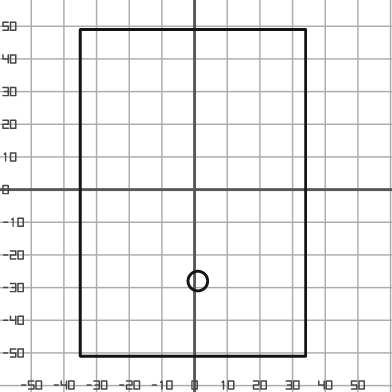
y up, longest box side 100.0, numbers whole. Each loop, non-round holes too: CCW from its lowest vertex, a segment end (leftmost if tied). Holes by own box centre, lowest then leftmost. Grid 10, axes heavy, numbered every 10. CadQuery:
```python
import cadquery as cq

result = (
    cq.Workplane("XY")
    .moveTo(-35.0, -51.0)
    .lineTo(34.0, -51.0)
    .lineTo(34.0, 49.0)
    .lineTo(-35.0, 49.0)
    .close()
    .moveTo(1.0, -28.0)
    .circle(3.0)
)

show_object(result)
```